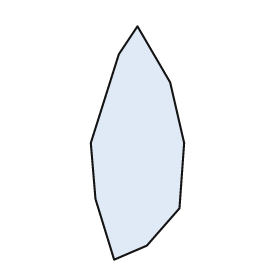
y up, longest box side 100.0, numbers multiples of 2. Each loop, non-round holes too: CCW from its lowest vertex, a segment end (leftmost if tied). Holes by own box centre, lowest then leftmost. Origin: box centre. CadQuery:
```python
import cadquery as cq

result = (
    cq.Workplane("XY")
    .moveTo(-10.0, -50.0)
    .lineTo(4.0, -44.0)
    .lineTo(18.0, -28.0)
    .lineTo(20.0, 0.0)
    .lineTo(14.0, 26.0)
    .lineTo(0.0, 50.0)
    .lineTo(-8.0, 38.0)
    .lineTo(-20.0, 0.0)
    .lineTo(-18.0, -24.0)
    .close()
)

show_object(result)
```